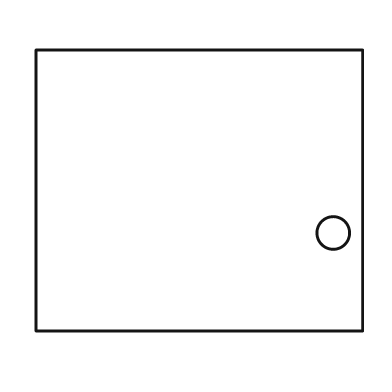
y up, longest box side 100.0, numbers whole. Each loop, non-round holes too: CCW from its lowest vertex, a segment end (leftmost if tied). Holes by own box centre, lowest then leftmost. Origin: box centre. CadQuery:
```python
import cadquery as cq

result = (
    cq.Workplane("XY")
    .moveTo(-50.0, -43.0)
    .lineTo(50.0, -43.0)
    .lineTo(50.0, 43.0)
    .lineTo(-50.0, 43.0)
    .close()
    .moveTo(41.0, -13.0)
    .circle(5.0)
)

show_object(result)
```